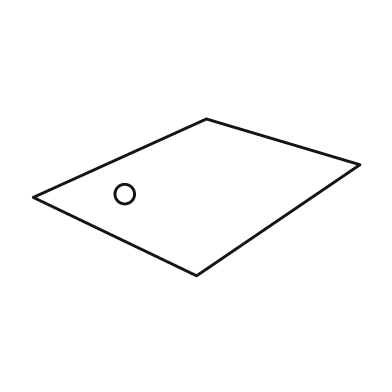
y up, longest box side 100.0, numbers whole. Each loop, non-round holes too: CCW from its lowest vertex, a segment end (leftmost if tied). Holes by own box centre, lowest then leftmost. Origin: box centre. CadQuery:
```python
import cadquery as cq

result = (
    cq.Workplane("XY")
    .moveTo(0.0, -24.0)
    .lineTo(50.0, 10.0)
    .lineTo(3.0, 24.0)
    .lineTo(-50.0, 0.0)
    .close()
    .moveTo(-22.0, 1.0)
    .circle(3.0)
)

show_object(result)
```